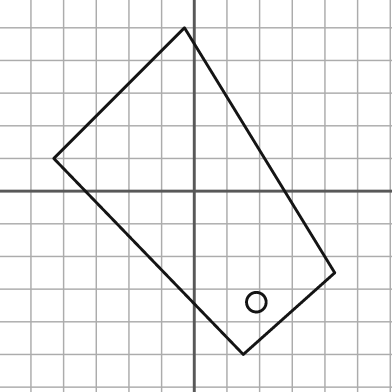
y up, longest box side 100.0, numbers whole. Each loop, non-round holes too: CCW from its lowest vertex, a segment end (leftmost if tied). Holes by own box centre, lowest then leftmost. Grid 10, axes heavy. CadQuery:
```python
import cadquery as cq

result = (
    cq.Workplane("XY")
    .moveTo(15.0, -50.0)
    .lineTo(43.0, -25.0)
    .lineTo(-3.0, 50.0)
    .lineTo(-43.0, 10.0)
    .close()
    .moveTo(19.0, -34.0)
    .circle(3.0)
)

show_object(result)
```